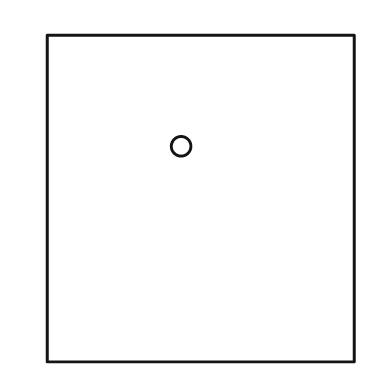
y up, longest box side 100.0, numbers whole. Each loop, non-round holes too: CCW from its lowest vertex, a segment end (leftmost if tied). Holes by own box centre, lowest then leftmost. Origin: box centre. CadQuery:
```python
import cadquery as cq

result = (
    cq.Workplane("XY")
    .moveTo(-47.0, -50.0)
    .lineTo(47.0, -50.0)
    .lineTo(47.0, 50.0)
    .lineTo(-47.0, 50.0)
    .close()
    .moveTo(-6.0, 16.0)
    .circle(3.0)
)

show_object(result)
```